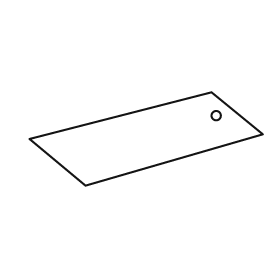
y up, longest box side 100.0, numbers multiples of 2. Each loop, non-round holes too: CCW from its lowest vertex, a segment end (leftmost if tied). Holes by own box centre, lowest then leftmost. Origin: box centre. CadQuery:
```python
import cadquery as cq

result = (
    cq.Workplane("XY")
    .moveTo(-26.0, -20.0)
    .lineTo(50.0, 2.0)
    .lineTo(28.0, 20.0)
    .lineTo(-50.0, 0.0)
    .close()
    .moveTo(30.0, 10.0)
    .circle(2.0)
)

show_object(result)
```